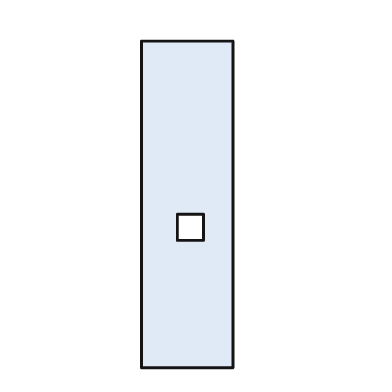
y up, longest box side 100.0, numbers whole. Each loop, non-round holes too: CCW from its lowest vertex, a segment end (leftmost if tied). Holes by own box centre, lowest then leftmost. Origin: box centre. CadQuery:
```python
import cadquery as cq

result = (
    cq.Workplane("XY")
    .moveTo(-14.0, -50.0)
    .lineTo(14.0, -50.0)
    .lineTo(14.0, 50.0)
    .lineTo(-14.0, 50.0)
    .close()
    .moveTo(-3.0, -11.0)
    .lineTo(5.0, -11.0)
    .lineTo(5.0, -3.0)
    .lineTo(-3.0, -3.0)
    .close()
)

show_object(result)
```